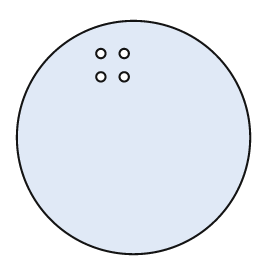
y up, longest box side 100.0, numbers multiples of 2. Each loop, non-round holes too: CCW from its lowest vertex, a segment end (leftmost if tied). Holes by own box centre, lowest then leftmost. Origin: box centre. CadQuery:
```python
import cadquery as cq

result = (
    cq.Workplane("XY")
    .moveTo(0.0, 0.0)
    .circle(50.0)
    .moveTo(-14.0, 26.0)
    .circle(2.0)
    .moveTo(-4.0, 26.0)
    .circle(2.0)
    .moveTo(-14.0, 36.0)
    .circle(2.0)
    .moveTo(-4.0, 36.0)
    .circle(2.0)
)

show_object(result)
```